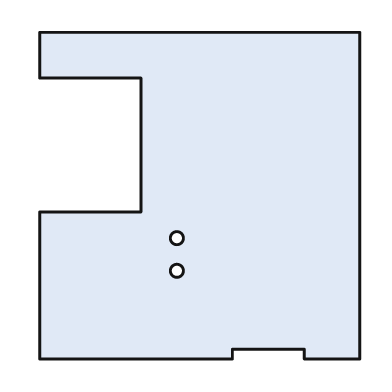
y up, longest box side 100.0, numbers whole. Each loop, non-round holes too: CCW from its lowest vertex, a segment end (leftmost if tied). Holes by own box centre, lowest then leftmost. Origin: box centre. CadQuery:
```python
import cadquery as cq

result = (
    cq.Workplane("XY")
    .moveTo(-49.0, -50.0)
    .lineTo(10.0, -50.0)
    .lineTo(10.0, -47.0)
    .lineTo(32.0, -47.0)
    .lineTo(32.0, -50.0)
    .lineTo(49.0, -50.0)
    .lineTo(49.0, 50.0)
    .lineTo(-49.0, 50.0)
    .lineTo(-49.0, 36.0)
    .lineTo(-18.0, 36.0)
    .lineTo(-18.0, -5.0)
    .lineTo(-49.0, -5.0)
    .close()
    .moveTo(-7.0, -23.0)
    .circle(2.0)
    .moveTo(-7.0, -13.0)
    .circle(2.0)
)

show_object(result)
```